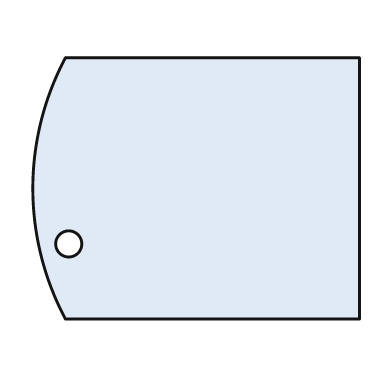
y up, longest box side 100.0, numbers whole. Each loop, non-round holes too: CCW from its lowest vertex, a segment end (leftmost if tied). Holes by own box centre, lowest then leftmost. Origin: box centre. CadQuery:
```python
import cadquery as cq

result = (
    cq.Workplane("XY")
    .moveTo(-40.0, -40.0)
    .lineTo(50.0, -40.0)
    .lineTo(50.0, 40.0)
    .lineTo(-40.0, 40.0)
    .threePointArc((-50.0, 0.0), (-40.0, -40.0))
    .close()
    .moveTo(-39.0, -17.0)
    .circle(4.0)
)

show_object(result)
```